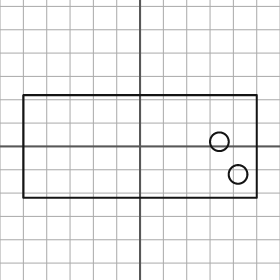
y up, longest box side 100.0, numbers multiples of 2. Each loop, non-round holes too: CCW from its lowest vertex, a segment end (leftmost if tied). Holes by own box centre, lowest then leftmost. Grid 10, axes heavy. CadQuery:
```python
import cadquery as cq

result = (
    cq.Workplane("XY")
    .moveTo(-50.0, -22.0)
    .lineTo(50.0, -22.0)
    .lineTo(50.0, 22.0)
    .lineTo(-50.0, 22.0)
    .close()
    .moveTo(42.0, -12.0)
    .circle(4.0)
    .moveTo(34.0, 2.0)
    .circle(4.0)
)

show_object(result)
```